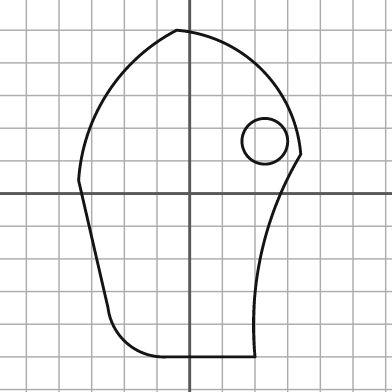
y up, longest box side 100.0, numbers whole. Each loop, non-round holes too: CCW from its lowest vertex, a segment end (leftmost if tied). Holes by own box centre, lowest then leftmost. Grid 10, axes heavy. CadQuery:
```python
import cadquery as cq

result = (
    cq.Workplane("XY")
    .moveTo(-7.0, -50.0)
    .lineTo(20.0, -50.0)
    .threePointArc((22.0, -18.0), (34.0, 12.0))
    .threePointArc((22.0, 38.0), (-4.0, 50.0))
    .threePointArc((-25.0, 31.0), (-34.0, 4.0))
    .lineTo(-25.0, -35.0)
    .threePointArc((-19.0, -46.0), (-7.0, -50.0))
    .close()
    .moveTo(23.0, 16.0)
    .circle(7.0)
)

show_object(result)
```